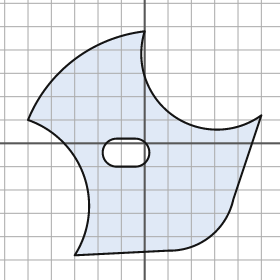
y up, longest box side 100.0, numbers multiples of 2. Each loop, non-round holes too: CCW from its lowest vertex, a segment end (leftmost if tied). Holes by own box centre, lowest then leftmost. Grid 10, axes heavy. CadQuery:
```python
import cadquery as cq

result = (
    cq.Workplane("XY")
    .moveTo(-30.0, -48.0)
    .lineTo(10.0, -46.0)
    .threePointArc((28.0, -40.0), (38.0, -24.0))
    .lineTo(50.0, 12.0)
    .threePointArc((12.0, 12.0), (0.0, 48.0))
    .threePointArc((-30.0, 36.0), (-50.0, 10.0))
    .threePointArc((-26.0, -14.0), (-30.0, -48.0))
    .close()
    .moveTo(-12.0, -10.0)
    .lineTo(-4.0, -10.0)
    .threePointArc((2.0, -4.0), (-4.0, 2.0))
    .lineTo(-12.0, 2.0)
    .threePointArc((-18.0, -4.0), (-12.0, -10.0))
    .close()
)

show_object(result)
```